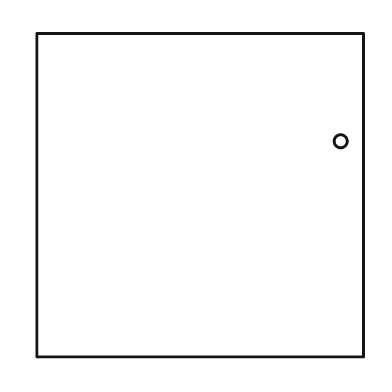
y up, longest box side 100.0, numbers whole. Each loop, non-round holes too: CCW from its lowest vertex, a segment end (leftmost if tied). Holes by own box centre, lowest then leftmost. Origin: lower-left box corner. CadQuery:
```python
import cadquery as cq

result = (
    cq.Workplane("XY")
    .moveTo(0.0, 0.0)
    .lineTo(100.0, 0.0)
    .lineTo(100.0, 99.0)
    .lineTo(0.0, 99.0)
    .close()
    .moveTo(93.0, 66.0)
    .circle(2.0)
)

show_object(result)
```